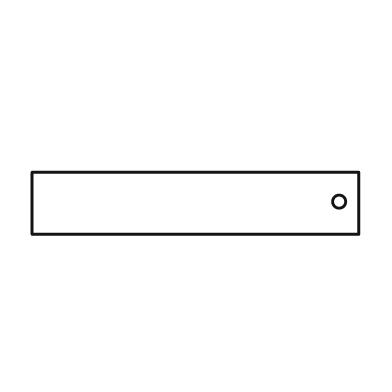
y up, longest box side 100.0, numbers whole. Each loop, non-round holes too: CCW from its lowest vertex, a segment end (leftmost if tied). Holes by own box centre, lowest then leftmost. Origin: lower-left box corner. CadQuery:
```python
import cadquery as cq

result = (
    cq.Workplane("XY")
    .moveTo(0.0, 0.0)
    .lineTo(100.0, 0.0)
    .lineTo(100.0, 19.0)
    .lineTo(0.0, 19.0)
    .close()
    .moveTo(94.0, 10.0)
    .circle(2.0)
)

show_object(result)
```